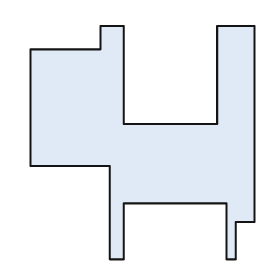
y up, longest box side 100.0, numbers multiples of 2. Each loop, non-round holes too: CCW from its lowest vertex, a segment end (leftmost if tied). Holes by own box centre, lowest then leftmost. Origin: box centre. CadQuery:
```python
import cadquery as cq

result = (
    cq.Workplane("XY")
    .moveTo(-14.0, -50.0)
    .lineTo(-8.0, -50.0)
    .lineTo(-8.0, -26.0)
    .lineTo(36.0, -26.0)
    .lineTo(36.0, -50.0)
    .lineTo(40.0, -50.0)
    .lineTo(40.0, -34.0)
    .lineTo(48.0, -34.0)
    .lineTo(48.0, 50.0)
    .lineTo(32.0, 50.0)
    .lineTo(32.0, 8.0)
    .lineTo(-8.0, 8.0)
    .lineTo(-8.0, 50.0)
    .lineTo(-18.0, 50.0)
    .lineTo(-18.0, 40.0)
    .lineTo(-48.0, 40.0)
    .lineTo(-48.0, -10.0)
    .lineTo(-14.0, -10.0)
    .close()
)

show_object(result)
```